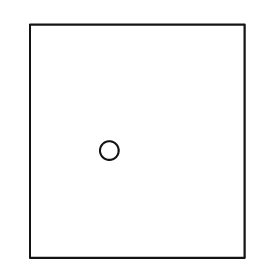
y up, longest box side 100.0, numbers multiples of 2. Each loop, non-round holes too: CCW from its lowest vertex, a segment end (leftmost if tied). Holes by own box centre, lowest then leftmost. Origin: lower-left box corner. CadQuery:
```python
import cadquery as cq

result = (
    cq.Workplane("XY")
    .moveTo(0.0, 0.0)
    .lineTo(92.0, 0.0)
    .lineTo(92.0, 100.0)
    .lineTo(0.0, 100.0)
    .close()
    .moveTo(34.0, 46.0)
    .circle(4.0)
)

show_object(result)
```